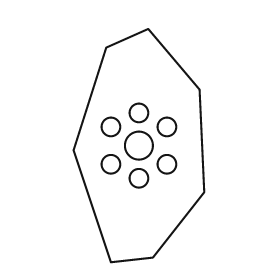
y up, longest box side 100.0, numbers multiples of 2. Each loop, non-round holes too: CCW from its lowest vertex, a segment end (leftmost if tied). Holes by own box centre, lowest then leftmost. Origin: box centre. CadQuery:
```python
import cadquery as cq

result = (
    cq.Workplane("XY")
    .moveTo(-12.0, -50.0)
    .lineTo(6.0, -48.0)
    .lineTo(28.0, -20.0)
    .lineTo(26.0, 24.0)
    .lineTo(4.0, 50.0)
    .lineTo(-14.0, 42.0)
    .lineTo(-28.0, -2.0)
    .close()
    .moveTo(0.0, -14.0)
    .circle(4.0)
    .moveTo(-12.0, -8.0)
    .circle(4.0)
    .moveTo(12.0, -8.0)
    .circle(4.0)
    .moveTo(0.0, 0.0)
    .circle(6.0)
    .moveTo(-12.0, 8.0)
    .circle(4.0)
    .moveTo(12.0, 8.0)
    .circle(4.0)
    .moveTo(0.0, 14.0)
    .circle(4.0)
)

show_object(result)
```